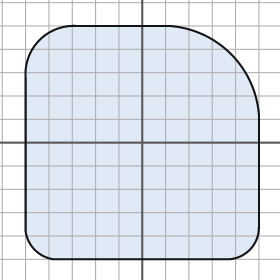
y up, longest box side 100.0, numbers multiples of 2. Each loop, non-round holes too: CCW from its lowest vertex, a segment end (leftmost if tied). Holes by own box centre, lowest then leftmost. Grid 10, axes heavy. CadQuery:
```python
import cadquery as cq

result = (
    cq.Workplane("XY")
    .moveTo(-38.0, -50.0)
    .lineTo(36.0, -50.0)
    .threePointArc((46.0, -46.0), (50.0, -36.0))
    .lineTo(50.0, 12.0)
    .threePointArc((38.0, 38.0), (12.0, 50.0))
    .lineTo(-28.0, 50.0)
    .threePointArc((-44.0, 44.0), (-50.0, 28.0))
    .lineTo(-50.0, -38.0)
    .threePointArc((-46.0, -46.0), (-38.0, -50.0))
    .close()
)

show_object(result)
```